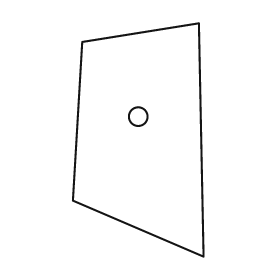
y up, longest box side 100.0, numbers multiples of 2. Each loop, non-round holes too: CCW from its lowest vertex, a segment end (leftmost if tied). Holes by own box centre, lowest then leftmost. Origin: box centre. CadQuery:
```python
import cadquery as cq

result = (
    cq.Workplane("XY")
    .moveTo(28.0, -50.0)
    .lineTo(26.0, 50.0)
    .lineTo(-24.0, 42.0)
    .lineTo(-28.0, -26.0)
    .close()
    .moveTo(0.0, 10.0)
    .circle(4.0)
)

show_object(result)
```